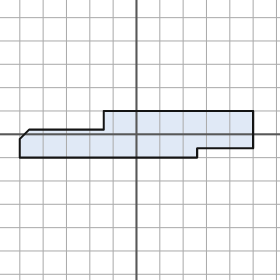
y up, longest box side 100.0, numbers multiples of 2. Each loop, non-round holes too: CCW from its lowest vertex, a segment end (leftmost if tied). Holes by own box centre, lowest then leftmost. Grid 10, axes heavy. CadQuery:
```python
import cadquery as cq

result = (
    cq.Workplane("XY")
    .moveTo(-50.0, -10.0)
    .lineTo(26.0, -10.0)
    .lineTo(26.0, -6.0)
    .lineTo(50.0, -6.0)
    .lineTo(50.0, 10.0)
    .lineTo(-14.0, 10.0)
    .lineTo(-14.0, 2.0)
    .lineTo(-46.0, 2.0)
    .lineTo(-50.0, -2.0)
    .close()
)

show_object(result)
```